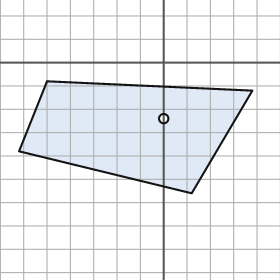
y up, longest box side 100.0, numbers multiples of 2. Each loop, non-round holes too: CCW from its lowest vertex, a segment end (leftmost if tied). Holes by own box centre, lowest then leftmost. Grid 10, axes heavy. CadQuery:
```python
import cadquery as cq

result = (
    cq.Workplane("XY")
    .moveTo(12.0, -56.0)
    .lineTo(38.0, -12.0)
    .lineTo(-50.0, -8.0)
    .lineTo(-62.0, -38.0)
    .close()
    .moveTo(0.0, -24.0)
    .circle(2.0)
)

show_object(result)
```